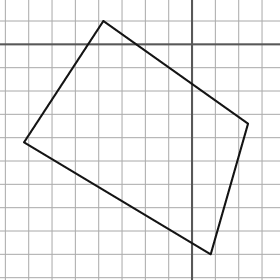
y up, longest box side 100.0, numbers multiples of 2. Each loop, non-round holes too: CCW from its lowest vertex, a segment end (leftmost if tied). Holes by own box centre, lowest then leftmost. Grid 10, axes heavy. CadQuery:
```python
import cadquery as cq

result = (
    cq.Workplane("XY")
    .moveTo(8.0, -90.0)
    .lineTo(24.0, -34.0)
    .lineTo(-38.0, 10.0)
    .lineTo(-72.0, -42.0)
    .close()
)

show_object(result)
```